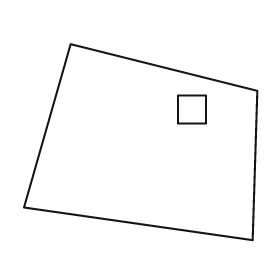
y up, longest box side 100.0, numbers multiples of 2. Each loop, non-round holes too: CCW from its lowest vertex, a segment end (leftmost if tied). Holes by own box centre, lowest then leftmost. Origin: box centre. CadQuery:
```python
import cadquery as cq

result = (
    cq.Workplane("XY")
    .moveTo(48.0, -42.0)
    .lineTo(50.0, 22.0)
    .lineTo(-30.0, 42.0)
    .lineTo(-50.0, -28.0)
    .close()
    .moveTo(16.0, 8.0)
    .lineTo(28.0, 8.0)
    .lineTo(28.0, 20.0)
    .lineTo(16.0, 20.0)
    .close()
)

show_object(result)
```